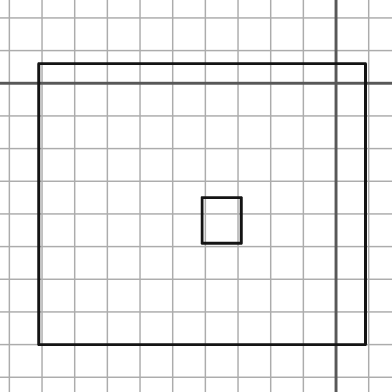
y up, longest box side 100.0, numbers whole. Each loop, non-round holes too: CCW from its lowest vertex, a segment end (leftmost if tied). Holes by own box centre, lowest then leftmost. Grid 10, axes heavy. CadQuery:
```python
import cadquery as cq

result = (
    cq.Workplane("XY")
    .moveTo(-91.0, -80.0)
    .lineTo(9.0, -80.0)
    .lineTo(9.0, 6.0)
    .lineTo(-91.0, 6.0)
    .close()
    .moveTo(-41.0, -49.0)
    .lineTo(-29.0, -49.0)
    .lineTo(-29.0, -35.0)
    .lineTo(-41.0, -35.0)
    .close()
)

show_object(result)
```